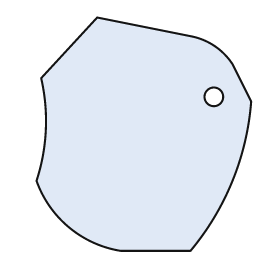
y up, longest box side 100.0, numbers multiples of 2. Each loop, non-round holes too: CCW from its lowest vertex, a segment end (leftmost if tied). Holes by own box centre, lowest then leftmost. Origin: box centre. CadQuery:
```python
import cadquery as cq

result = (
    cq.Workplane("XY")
    .moveTo(-10.0, -50.0)
    .lineTo(20.0, -50.0)
    .threePointArc((38.0, -20.0), (46.0, 14.0))
    .lineTo(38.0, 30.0)
    .threePointArc((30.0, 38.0), (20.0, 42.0))
    .lineTo(-20.0, 50.0)
    .lineTo(-44.0, 24.0)
    .threePointArc((-42.0, 2.0), (-46.0, -20.0))
    .threePointArc((-32.0, -40.0), (-10.0, -50.0))
    .close()
    .moveTo(30.0, 16.0)
    .circle(4.0)
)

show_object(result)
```